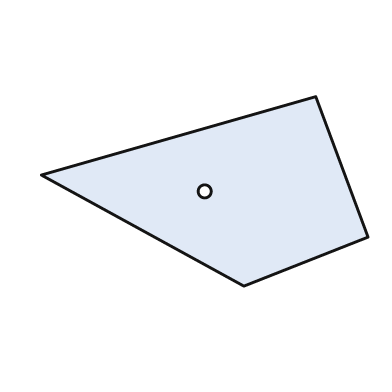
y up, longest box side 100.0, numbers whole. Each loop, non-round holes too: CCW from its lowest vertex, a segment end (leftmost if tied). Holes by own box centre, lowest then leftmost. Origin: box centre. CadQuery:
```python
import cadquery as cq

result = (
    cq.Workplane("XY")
    .moveTo(12.0, -29.0)
    .lineTo(50.0, -14.0)
    .lineTo(34.0, 29.0)
    .lineTo(-50.0, 5.0)
    .close()
    .moveTo(0.0, 0.0)
    .circle(2.0)
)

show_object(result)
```